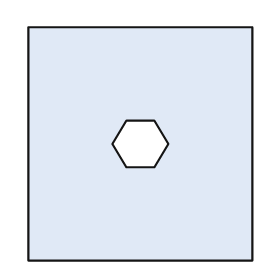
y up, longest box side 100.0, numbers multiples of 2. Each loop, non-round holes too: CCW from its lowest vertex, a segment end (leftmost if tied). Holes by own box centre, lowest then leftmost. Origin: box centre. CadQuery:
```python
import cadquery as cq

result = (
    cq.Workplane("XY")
    .moveTo(-48.0, -50.0)
    .lineTo(48.0, -50.0)
    .lineTo(48.0, 50.0)
    .lineTo(-48.0, 50.0)
    .close()
    .moveTo(-6.0, -10.0)
    .lineTo(6.0, -10.0)
    .lineTo(12.0, 0.0)
    .lineTo(6.0, 10.0)
    .lineTo(-6.0, 10.0)
    .lineTo(-12.0, 0.0)
    .close()
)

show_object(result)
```